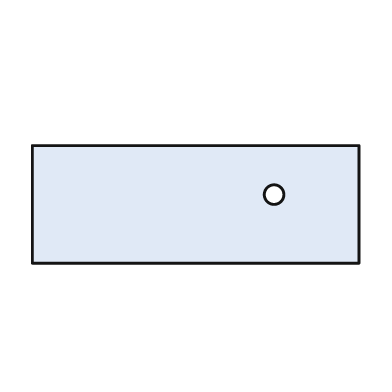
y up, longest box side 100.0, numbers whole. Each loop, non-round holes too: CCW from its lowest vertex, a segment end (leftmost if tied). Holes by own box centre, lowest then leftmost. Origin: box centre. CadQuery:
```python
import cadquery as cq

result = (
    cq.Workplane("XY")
    .moveTo(-50.0, -18.0)
    .lineTo(50.0, -18.0)
    .lineTo(50.0, 18.0)
    .lineTo(-50.0, 18.0)
    .close()
    .moveTo(24.0, 3.0)
    .circle(3.0)
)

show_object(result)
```